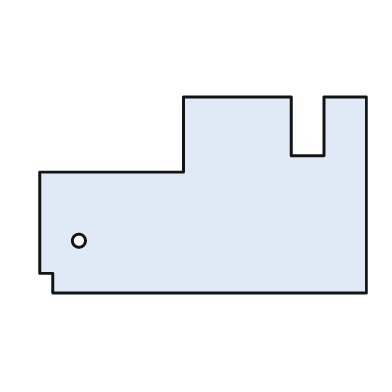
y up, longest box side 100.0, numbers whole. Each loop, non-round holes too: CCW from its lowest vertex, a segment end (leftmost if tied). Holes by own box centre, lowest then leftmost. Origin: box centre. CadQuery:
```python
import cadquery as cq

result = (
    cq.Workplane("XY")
    .moveTo(-46.0, -30.0)
    .lineTo(50.0, -30.0)
    .lineTo(50.0, 30.0)
    .lineTo(37.0, 30.0)
    .lineTo(37.0, 12.0)
    .lineTo(27.0, 12.0)
    .lineTo(27.0, 30.0)
    .lineTo(-6.0, 30.0)
    .lineTo(-6.0, 7.0)
    .lineTo(-50.0, 7.0)
    .lineTo(-50.0, -24.0)
    .lineTo(-46.0, -24.0)
    .close()
    .moveTo(-38.0, -14.0)
    .circle(2.0)
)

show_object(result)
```